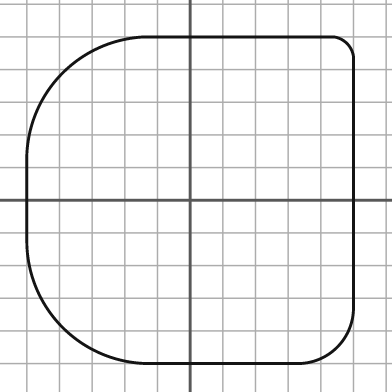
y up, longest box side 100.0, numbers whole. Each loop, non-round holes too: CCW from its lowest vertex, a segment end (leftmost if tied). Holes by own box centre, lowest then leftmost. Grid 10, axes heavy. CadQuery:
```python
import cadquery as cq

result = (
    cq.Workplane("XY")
    .moveTo(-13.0, -50.0)
    .lineTo(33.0, -50.0)
    .threePointArc((45.0, -45.0), (50.0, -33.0))
    .lineTo(50.0, 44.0)
    .threePointArc((48.0, 48.0), (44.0, 50.0))
    .lineTo(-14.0, 50.0)
    .threePointArc((-39.0, 39.0), (-50.0, 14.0))
    .lineTo(-50.0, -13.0)
    .threePointArc((-39.0, -39.0), (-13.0, -50.0))
    .close()
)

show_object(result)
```